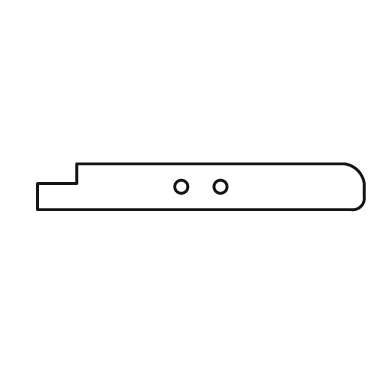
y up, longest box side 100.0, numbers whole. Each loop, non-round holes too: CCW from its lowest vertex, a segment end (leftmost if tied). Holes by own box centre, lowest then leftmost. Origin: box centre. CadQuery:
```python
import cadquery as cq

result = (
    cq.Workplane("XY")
    .moveTo(-50.0, -7.0)
    .lineTo(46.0, -7.0)
    .threePointArc((49.0, -6.0), (50.0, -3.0))
    .lineTo(50.0, 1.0)
    .threePointArc((48.0, 5.0), (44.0, 7.0))
    .lineTo(-38.0, 7.0)
    .lineTo(-38.0, 1.0)
    .lineTo(-50.0, 1.0)
    .close()
    .moveTo(-6.0, 0.0)
    .circle(2.0)
    .moveTo(6.0, 0.0)
    .circle(2.0)
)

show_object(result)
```